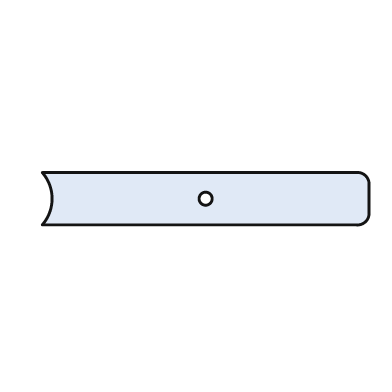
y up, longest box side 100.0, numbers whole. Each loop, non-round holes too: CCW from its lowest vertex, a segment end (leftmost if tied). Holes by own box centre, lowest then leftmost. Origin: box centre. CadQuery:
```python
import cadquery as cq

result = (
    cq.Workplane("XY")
    .moveTo(-50.0, -8.0)
    .lineTo(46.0, -8.0)
    .threePointArc((49.0, -7.0), (50.0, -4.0))
    .lineTo(50.0, 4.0)
    .threePointArc((49.0, 7.0), (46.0, 8.0))
    .lineTo(-50.0, 8.0)
    .threePointArc((-47.0, 0.0), (-50.0, -8.0))
    .close()
    .moveTo(0.0, 0.0)
    .circle(2.0)
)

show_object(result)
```